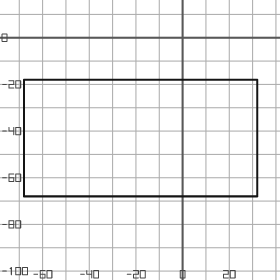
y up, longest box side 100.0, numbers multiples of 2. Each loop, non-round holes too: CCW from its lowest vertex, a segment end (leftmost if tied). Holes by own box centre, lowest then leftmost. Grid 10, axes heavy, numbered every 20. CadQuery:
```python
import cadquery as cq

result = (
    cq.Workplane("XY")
    .moveTo(-68.0, -68.0)
    .lineTo(32.0, -68.0)
    .lineTo(32.0, -18.0)
    .lineTo(-68.0, -18.0)
    .close()
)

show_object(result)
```